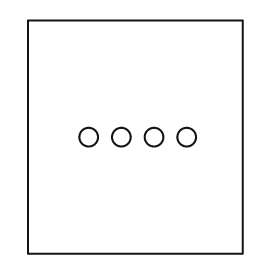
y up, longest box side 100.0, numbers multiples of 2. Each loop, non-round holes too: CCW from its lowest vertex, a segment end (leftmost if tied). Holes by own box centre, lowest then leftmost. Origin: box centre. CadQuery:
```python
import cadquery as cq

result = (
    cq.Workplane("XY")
    .moveTo(-46.0, -50.0)
    .lineTo(46.0, -50.0)
    .lineTo(46.0, 50.0)
    .lineTo(-46.0, 50.0)
    .close()
    .moveTo(-20.0, 0.0)
    .circle(4.0)
    .moveTo(-6.0, 0.0)
    .circle(4.0)
    .moveTo(8.0, 0.0)
    .circle(4.0)
    .moveTo(22.0, 0.0)
    .circle(4.0)
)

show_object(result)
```